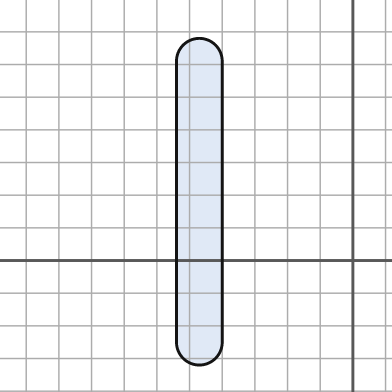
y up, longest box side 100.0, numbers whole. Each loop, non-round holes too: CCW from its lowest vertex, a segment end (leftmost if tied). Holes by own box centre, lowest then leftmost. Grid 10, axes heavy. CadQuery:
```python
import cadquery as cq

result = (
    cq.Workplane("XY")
    .moveTo(-54.0, -25.0)
    .threePointArc((-47.0, -32.0), (-40.0, -25.0))
    .lineTo(-40.0, 61.0)
    .threePointArc((-47.0, 68.0), (-54.0, 61.0))
    .close()
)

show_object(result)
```